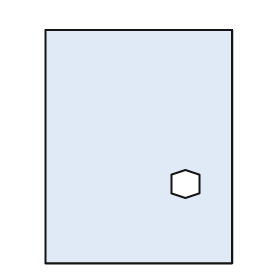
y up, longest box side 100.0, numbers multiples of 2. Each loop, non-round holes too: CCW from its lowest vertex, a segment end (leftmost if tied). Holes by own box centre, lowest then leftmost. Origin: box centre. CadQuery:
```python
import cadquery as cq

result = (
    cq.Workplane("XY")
    .moveTo(-40.0, -50.0)
    .lineTo(40.0, -50.0)
    .lineTo(40.0, 50.0)
    .lineTo(-40.0, 50.0)
    .close()
    .moveTo(20.0, -22.0)
    .lineTo(26.0, -20.0)
    .lineTo(26.0, -12.0)
    .lineTo(20.0, -10.0)
    .lineTo(14.0, -12.0)
    .lineTo(14.0, -20.0)
    .close()
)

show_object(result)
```